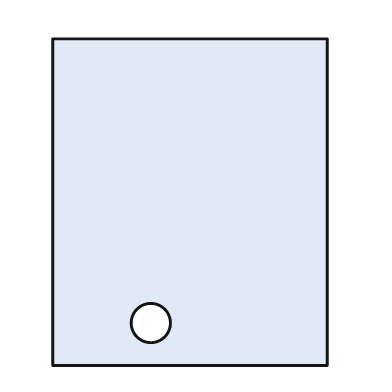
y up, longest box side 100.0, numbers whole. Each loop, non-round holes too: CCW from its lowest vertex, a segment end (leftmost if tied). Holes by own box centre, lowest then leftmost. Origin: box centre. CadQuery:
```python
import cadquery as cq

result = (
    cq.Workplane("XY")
    .moveTo(-42.0, -50.0)
    .lineTo(42.0, -50.0)
    .lineTo(42.0, 50.0)
    .lineTo(-42.0, 50.0)
    .close()
    .moveTo(-12.0, -37.0)
    .circle(6.0)
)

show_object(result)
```